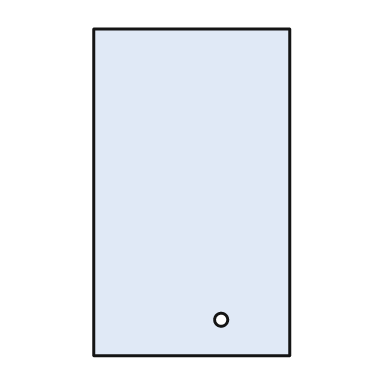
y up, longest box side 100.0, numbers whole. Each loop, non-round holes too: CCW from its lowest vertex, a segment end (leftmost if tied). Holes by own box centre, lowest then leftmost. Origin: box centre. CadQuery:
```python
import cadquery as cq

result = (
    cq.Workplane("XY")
    .moveTo(-30.0, -50.0)
    .lineTo(30.0, -50.0)
    .lineTo(30.0, 50.0)
    .lineTo(-30.0, 50.0)
    .close()
    .moveTo(9.0, -39.0)
    .circle(2.0)
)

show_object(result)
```